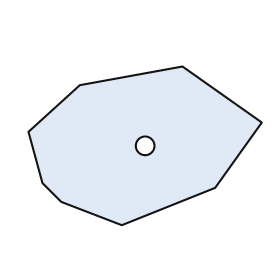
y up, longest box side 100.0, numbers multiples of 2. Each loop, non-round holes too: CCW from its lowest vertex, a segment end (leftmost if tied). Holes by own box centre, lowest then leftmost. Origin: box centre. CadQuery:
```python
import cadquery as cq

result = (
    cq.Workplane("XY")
    .moveTo(-10.0, -34.0)
    .lineTo(30.0, -18.0)
    .lineTo(50.0, 10.0)
    .lineTo(16.0, 34.0)
    .lineTo(-28.0, 26.0)
    .lineTo(-50.0, 6.0)
    .lineTo(-44.0, -16.0)
    .lineTo(-36.0, -24.0)
    .close()
    .moveTo(0.0, 0.0)
    .circle(4.0)
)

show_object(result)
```